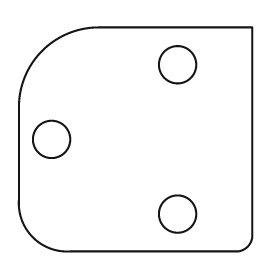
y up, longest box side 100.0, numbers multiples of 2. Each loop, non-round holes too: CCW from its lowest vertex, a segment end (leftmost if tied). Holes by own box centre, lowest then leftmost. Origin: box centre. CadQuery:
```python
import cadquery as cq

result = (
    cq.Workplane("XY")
    .moveTo(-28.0, -48.0)
    .lineTo(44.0, -48.0)
    .threePointArc((48.0, -46.0), (50.0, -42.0))
    .lineTo(50.0, 48.0)
    .lineTo(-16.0, 48.0)
    .threePointArc((-40.0, 38.0), (-50.0, 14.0))
    .lineTo(-50.0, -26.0)
    .threePointArc((-44.0, -42.0), (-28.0, -48.0))
    .close()
    .moveTo(18.0, -32.0)
    .circle(8.0)
    .moveTo(-36.0, 0.0)
    .circle(8.0)
    .moveTo(18.0, 32.0)
    .circle(8.0)
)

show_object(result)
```